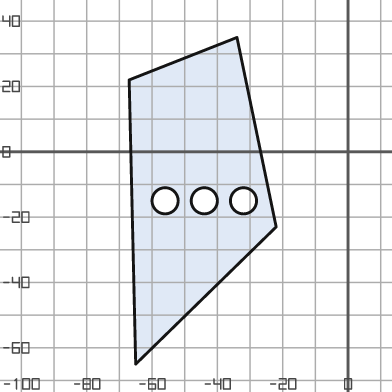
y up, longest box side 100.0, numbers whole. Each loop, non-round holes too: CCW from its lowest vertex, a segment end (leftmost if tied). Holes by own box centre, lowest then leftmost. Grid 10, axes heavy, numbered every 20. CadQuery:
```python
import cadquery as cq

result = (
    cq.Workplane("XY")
    .moveTo(-65.0, -65.0)
    .lineTo(-22.0, -23.0)
    .lineTo(-34.0, 35.0)
    .lineTo(-67.0, 22.0)
    .close()
    .moveTo(-56.0, -15.0)
    .circle(4.0)
    .moveTo(-44.0, -15.0)
    .circle(4.0)
    .moveTo(-32.0, -15.0)
    .circle(4.0)
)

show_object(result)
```